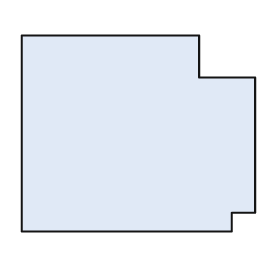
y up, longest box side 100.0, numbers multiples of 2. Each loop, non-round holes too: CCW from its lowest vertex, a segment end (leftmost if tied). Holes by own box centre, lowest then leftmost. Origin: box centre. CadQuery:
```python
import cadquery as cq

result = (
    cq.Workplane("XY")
    .moveTo(-50.0, -42.0)
    .lineTo(40.0, -42.0)
    .lineTo(40.0, -34.0)
    .lineTo(50.0, -34.0)
    .lineTo(50.0, 24.0)
    .lineTo(26.0, 24.0)
    .lineTo(26.0, 42.0)
    .lineTo(-50.0, 42.0)
    .close()
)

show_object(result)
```